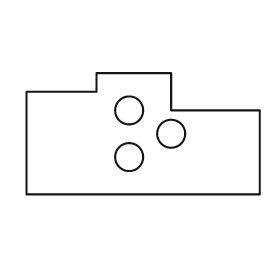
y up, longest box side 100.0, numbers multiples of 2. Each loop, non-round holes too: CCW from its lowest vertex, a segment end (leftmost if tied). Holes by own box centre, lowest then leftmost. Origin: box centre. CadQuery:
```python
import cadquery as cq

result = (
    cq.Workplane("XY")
    .moveTo(-50.0, -26.0)
    .lineTo(50.0, -26.0)
    .lineTo(50.0, 10.0)
    .lineTo(12.0, 10.0)
    .lineTo(12.0, 26.0)
    .lineTo(-20.0, 26.0)
    .lineTo(-20.0, 18.0)
    .lineTo(-50.0, 18.0)
    .close()
    .moveTo(-6.0, -10.0)
    .circle(6.0)
    .moveTo(12.0, 0.0)
    .circle(6.0)
    .moveTo(-6.0, 10.0)
    .circle(6.0)
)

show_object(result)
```